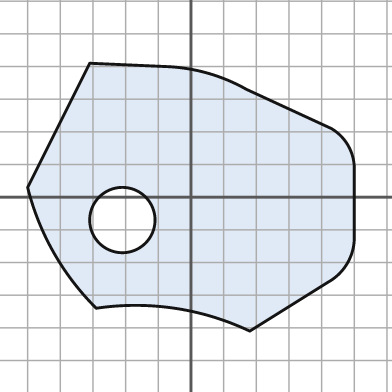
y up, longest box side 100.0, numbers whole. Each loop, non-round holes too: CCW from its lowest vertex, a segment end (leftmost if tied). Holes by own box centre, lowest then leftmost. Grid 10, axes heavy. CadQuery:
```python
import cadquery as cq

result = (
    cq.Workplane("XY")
    .moveTo(18.0, -41.0)
    .lineTo(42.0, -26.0)
    .threePointArc((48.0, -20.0), (50.0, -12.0))
    .lineTo(50.0, 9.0)
    .threePointArc((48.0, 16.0), (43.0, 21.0))
    .lineTo(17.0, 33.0)
    .threePointArc((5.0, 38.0), (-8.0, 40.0))
    .lineTo(-31.0, 41.0)
    .lineTo(-50.0, 3.0)
    .threePointArc((-42.0, -17.0), (-29.0, -34.0))
    .threePointArc((-5.0, -34.0), (18.0, -41.0))
    .close()
    .moveTo(-21.0, -7.0)
    .circle(10.0)
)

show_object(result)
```